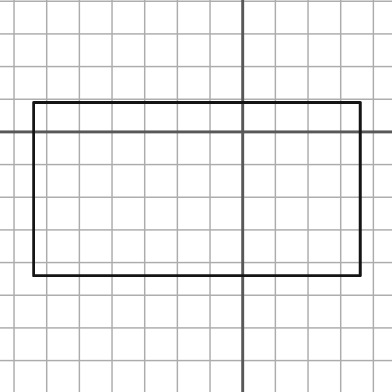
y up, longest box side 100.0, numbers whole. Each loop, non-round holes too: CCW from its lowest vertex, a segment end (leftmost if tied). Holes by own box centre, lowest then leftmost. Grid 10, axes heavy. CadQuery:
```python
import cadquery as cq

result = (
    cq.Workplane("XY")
    .moveTo(-64.0, -44.0)
    .lineTo(36.0, -44.0)
    .lineTo(36.0, 9.0)
    .lineTo(-64.0, 9.0)
    .close()
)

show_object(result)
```